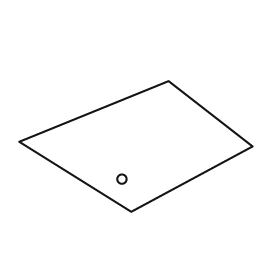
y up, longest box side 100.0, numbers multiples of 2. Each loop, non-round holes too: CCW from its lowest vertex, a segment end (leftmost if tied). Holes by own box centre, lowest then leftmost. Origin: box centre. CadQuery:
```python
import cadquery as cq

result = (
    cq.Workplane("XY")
    .moveTo(-2.0, -28.0)
    .lineTo(50.0, 0.0)
    .lineTo(14.0, 28.0)
    .lineTo(-50.0, 2.0)
    .close()
    .moveTo(-6.0, -14.0)
    .circle(2.0)
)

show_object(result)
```